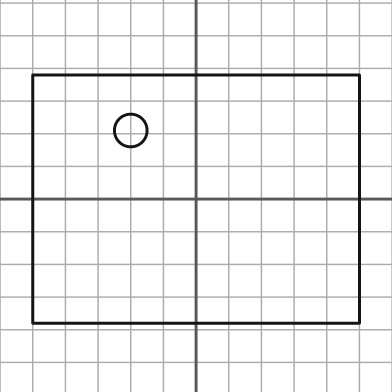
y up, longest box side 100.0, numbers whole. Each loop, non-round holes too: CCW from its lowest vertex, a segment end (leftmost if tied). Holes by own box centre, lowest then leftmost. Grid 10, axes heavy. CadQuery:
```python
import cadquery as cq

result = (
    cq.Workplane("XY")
    .moveTo(-50.0, -38.0)
    .lineTo(50.0, -38.0)
    .lineTo(50.0, 38.0)
    .lineTo(-50.0, 38.0)
    .close()
    .moveTo(-20.0, 21.0)
    .circle(5.0)
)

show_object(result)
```